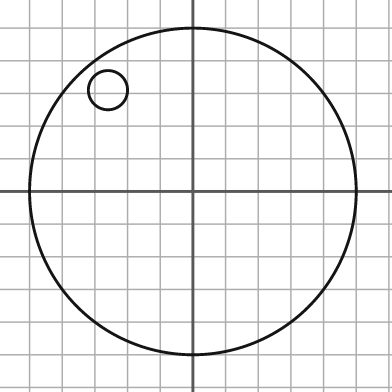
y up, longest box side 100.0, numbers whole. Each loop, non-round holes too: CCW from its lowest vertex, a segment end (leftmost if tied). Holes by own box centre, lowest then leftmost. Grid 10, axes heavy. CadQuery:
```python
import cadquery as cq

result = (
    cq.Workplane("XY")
    .moveTo(0.0, 0.0)
    .circle(50.0)
    .moveTo(-26.0, 31.0)
    .circle(6.0)
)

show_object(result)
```